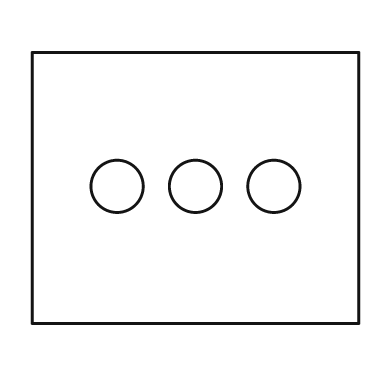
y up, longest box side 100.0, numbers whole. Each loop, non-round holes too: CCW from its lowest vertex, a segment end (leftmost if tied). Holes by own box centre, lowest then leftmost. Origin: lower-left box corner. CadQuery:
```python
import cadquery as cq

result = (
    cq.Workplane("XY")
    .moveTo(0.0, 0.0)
    .lineTo(100.0, 0.0)
    .lineTo(100.0, 83.0)
    .lineTo(0.0, 83.0)
    .close()
    .moveTo(26.0, 42.0)
    .circle(8.0)
    .moveTo(50.0, 42.0)
    .circle(8.0)
    .moveTo(74.0, 42.0)
    .circle(8.0)
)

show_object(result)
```